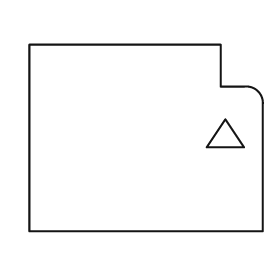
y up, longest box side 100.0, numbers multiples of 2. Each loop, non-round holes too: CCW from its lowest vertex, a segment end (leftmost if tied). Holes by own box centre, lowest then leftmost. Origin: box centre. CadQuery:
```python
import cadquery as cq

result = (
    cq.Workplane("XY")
    .moveTo(-50.0, -40.0)
    .lineTo(50.0, -40.0)
    .lineTo(50.0, 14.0)
    .threePointArc((48.0, 20.0), (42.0, 22.0))
    .lineTo(32.0, 22.0)
    .lineTo(32.0, 40.0)
    .lineTo(-50.0, 40.0)
    .close()
    .moveTo(26.0, -4.0)
    .lineTo(42.0, -4.0)
    .lineTo(34.0, 8.0)
    .close()
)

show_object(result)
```